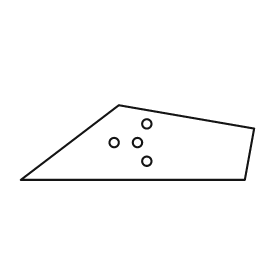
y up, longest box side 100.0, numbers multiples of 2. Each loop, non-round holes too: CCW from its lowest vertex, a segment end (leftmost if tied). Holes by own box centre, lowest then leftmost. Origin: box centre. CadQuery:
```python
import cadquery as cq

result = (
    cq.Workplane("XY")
    .moveTo(-50.0, -16.0)
    .lineTo(46.0, -16.0)
    .lineTo(50.0, 6.0)
    .lineTo(-8.0, 16.0)
    .close()
    .moveTo(4.0, -8.0)
    .circle(2.0)
    .moveTo(-10.0, 0.0)
    .circle(2.0)
    .moveTo(0.0, 0.0)
    .circle(2.0)
    .moveTo(4.0, 8.0)
    .circle(2.0)
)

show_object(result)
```